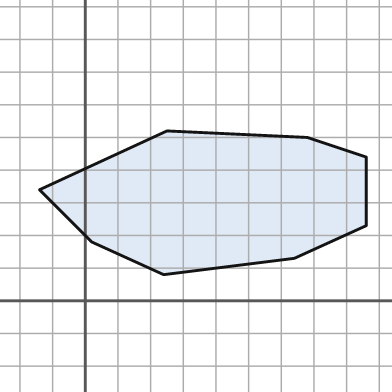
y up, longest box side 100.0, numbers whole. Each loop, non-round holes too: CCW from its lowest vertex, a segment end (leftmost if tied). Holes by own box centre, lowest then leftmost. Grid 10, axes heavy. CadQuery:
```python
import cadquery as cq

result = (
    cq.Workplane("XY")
    .moveTo(24.0, 8.0)
    .lineTo(64.0, 13.0)
    .lineTo(86.0, 23.0)
    .lineTo(86.0, 44.0)
    .lineTo(68.0, 50.0)
    .lineTo(25.0, 52.0)
    .lineTo(-14.0, 34.0)
    .lineTo(2.0, 18.0)
    .close()
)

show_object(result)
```